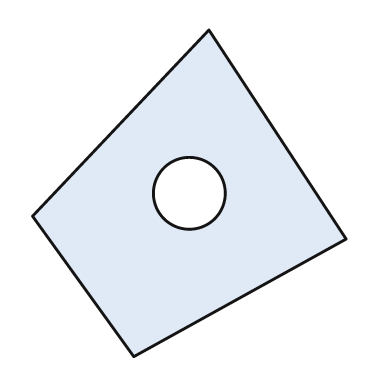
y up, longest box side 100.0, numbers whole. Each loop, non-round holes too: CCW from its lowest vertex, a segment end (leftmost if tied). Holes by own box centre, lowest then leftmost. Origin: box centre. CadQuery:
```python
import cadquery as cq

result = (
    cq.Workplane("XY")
    .moveTo(-17.0, -50.0)
    .lineTo(48.0, -14.0)
    .lineTo(6.0, 50.0)
    .lineTo(-48.0, -7.0)
    .close()
    .moveTo(0.0, 0.0)
    .circle(11.0)
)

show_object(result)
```